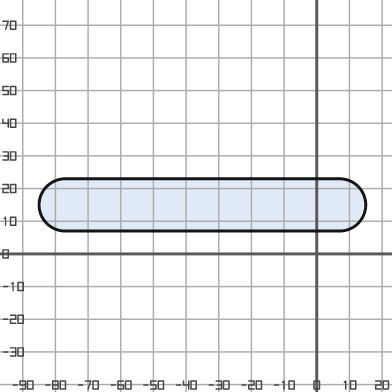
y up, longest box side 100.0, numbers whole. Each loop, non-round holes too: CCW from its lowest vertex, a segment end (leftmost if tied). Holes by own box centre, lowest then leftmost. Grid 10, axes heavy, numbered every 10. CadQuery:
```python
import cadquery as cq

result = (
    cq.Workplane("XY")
    .moveTo(-77.0, 7.0)
    .lineTo(7.0, 7.0)
    .threePointArc((15.0, 15.0), (7.0, 23.0))
    .lineTo(-77.0, 23.0)
    .threePointArc((-85.0, 15.0), (-77.0, 7.0))
    .close()
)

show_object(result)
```